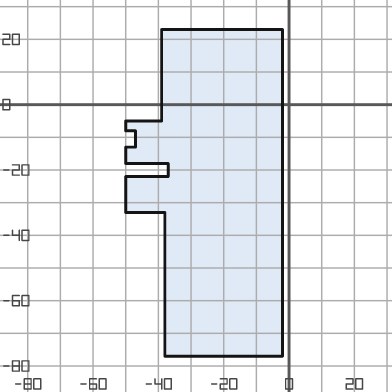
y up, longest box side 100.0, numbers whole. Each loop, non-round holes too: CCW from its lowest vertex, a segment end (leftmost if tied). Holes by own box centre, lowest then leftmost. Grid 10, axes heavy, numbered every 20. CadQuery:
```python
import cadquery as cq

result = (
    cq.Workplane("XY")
    .moveTo(-38.0, -77.0)
    .lineTo(-2.0, -77.0)
    .lineTo(-2.0, 23.0)
    .lineTo(-39.0, 23.0)
    .lineTo(-39.0, -5.0)
    .lineTo(-50.0, -5.0)
    .lineTo(-50.0, -8.0)
    .lineTo(-47.0, -8.0)
    .lineTo(-47.0, -13.0)
    .lineTo(-50.0, -13.0)
    .lineTo(-50.0, -18.0)
    .lineTo(-37.0, -18.0)
    .lineTo(-37.0, -22.0)
    .lineTo(-50.0, -22.0)
    .lineTo(-50.0, -33.0)
    .lineTo(-38.0, -33.0)
    .close()
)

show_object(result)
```